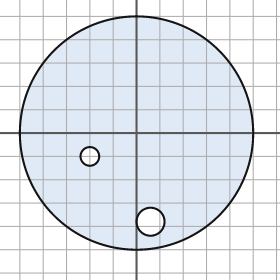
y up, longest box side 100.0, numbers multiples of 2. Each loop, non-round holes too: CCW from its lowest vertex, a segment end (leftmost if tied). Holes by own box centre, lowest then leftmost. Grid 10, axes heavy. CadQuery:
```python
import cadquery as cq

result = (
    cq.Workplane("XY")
    .moveTo(0.0, 0.0)
    .circle(50.0)
    .moveTo(6.0, -38.0)
    .circle(6.0)
    .moveTo(-20.0, -10.0)
    .circle(4.0)
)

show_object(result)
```